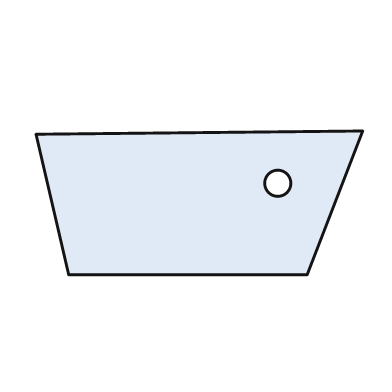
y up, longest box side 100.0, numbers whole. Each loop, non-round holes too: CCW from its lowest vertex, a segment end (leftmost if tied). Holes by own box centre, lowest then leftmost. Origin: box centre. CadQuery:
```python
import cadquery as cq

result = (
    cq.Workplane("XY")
    .moveTo(-40.0, -22.0)
    .lineTo(33.0, -22.0)
    .lineTo(50.0, 22.0)
    .lineTo(-50.0, 21.0)
    .close()
    .moveTo(24.0, 6.0)
    .circle(4.0)
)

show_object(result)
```